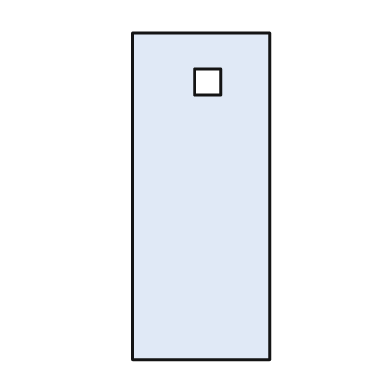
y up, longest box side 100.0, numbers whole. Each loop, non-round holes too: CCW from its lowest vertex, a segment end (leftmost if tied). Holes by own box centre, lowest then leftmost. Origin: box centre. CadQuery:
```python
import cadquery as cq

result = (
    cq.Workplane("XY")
    .moveTo(-21.0, -50.0)
    .lineTo(21.0, -50.0)
    .lineTo(21.0, 50.0)
    .lineTo(-21.0, 50.0)
    .close()
    .moveTo(-2.0, 31.0)
    .lineTo(6.0, 31.0)
    .lineTo(6.0, 39.0)
    .lineTo(-2.0, 39.0)
    .close()
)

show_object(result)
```